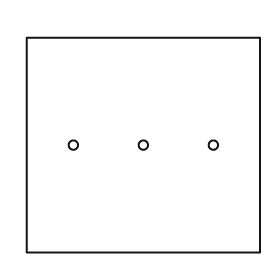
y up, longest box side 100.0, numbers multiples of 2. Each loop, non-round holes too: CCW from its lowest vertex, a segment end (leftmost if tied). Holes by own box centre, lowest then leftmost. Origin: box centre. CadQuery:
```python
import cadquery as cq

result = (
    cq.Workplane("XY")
    .moveTo(-50.0, -46.0)
    .lineTo(50.0, -46.0)
    .lineTo(50.0, 46.0)
    .lineTo(-50.0, 46.0)
    .close()
    .moveTo(-30.0, 0.0)
    .circle(2.0)
    .moveTo(0.0, 0.0)
    .circle(2.0)
    .moveTo(30.0, 0.0)
    .circle(2.0)
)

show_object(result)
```